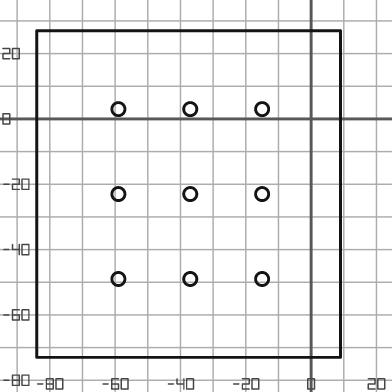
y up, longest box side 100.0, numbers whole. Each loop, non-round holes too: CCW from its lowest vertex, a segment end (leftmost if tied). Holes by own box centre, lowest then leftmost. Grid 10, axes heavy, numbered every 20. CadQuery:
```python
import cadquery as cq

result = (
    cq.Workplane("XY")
    .moveTo(-84.0, -73.0)
    .lineTo(9.0, -73.0)
    .lineTo(9.0, 27.0)
    .lineTo(-84.0, 27.0)
    .close()
    .moveTo(-59.0, -49.0)
    .circle(2.0)
    .moveTo(-37.0, -49.0)
    .circle(2.0)
    .moveTo(-15.0, -49.0)
    .circle(2.0)
    .moveTo(-59.0, -23.0)
    .circle(2.0)
    .moveTo(-37.0, -23.0)
    .circle(2.0)
    .moveTo(-15.0, -23.0)
    .circle(2.0)
    .moveTo(-59.0, 3.0)
    .circle(2.0)
    .moveTo(-37.0, 3.0)
    .circle(2.0)
    .moveTo(-15.0, 3.0)
    .circle(2.0)
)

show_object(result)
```